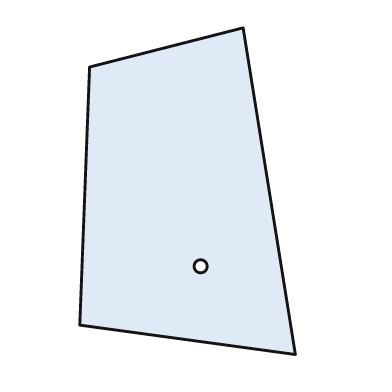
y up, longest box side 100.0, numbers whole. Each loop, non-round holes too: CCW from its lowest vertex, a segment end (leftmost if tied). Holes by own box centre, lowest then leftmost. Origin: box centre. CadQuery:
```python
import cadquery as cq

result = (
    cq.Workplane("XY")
    .moveTo(33.0, -50.0)
    .lineTo(17.0, 50.0)
    .lineTo(-30.0, 38.0)
    .lineTo(-33.0, -41.0)
    .close()
    .moveTo(4.0, -23.0)
    .circle(2.0)
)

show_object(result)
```